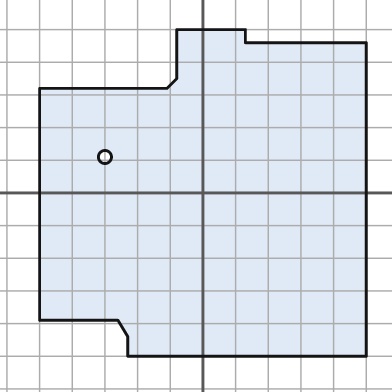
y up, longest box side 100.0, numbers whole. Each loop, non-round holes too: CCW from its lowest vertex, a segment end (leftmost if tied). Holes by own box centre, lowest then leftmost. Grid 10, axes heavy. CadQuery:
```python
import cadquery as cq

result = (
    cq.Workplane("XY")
    .moveTo(-23.0, -50.0)
    .lineTo(50.0, -50.0)
    .lineTo(50.0, 46.0)
    .lineTo(13.0, 46.0)
    .lineTo(13.0, 50.0)
    .lineTo(-8.0, 50.0)
    .lineTo(-8.0, 35.0)
    .lineTo(-11.0, 32.0)
    .lineTo(-50.0, 32.0)
    .lineTo(-50.0, -39.0)
    .lineTo(-26.0, -39.0)
    .lineTo(-23.0, -44.0)
    .close()
    .moveTo(-30.0, 11.0)
    .circle(2.0)
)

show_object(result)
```